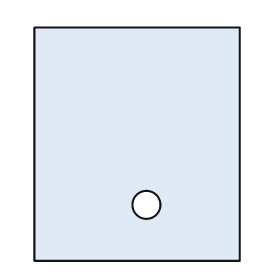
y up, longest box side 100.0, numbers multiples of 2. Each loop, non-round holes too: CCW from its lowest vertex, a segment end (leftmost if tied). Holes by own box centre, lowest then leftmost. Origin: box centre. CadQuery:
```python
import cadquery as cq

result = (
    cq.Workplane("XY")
    .moveTo(-44.0, -50.0)
    .lineTo(44.0, -50.0)
    .lineTo(44.0, 50.0)
    .lineTo(-44.0, 50.0)
    .close()
    .moveTo(4.0, -26.0)
    .circle(6.0)
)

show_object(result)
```